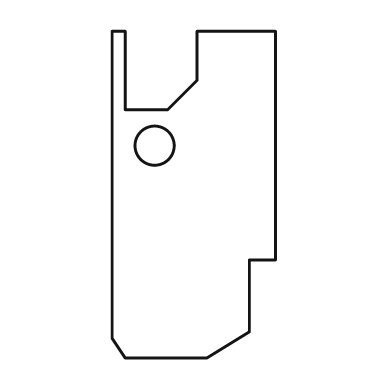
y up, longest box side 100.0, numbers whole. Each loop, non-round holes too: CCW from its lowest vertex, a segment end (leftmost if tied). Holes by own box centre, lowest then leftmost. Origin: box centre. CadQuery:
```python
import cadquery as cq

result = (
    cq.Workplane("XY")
    .moveTo(-21.0, -50.0)
    .lineTo(4.0, -50.0)
    .lineTo(17.0, -42.0)
    .lineTo(17.0, -20.0)
    .lineTo(25.0, -20.0)
    .lineTo(25.0, 50.0)
    .lineTo(1.0, 50.0)
    .lineTo(1.0, 35.0)
    .lineTo(-8.0, 26.0)
    .lineTo(-21.0, 26.0)
    .lineTo(-21.0, 50.0)
    .lineTo(-25.0, 50.0)
    .lineTo(-25.0, -44.0)
    .close()
    .moveTo(-12.0, 15.0)
    .circle(6.0)
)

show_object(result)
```